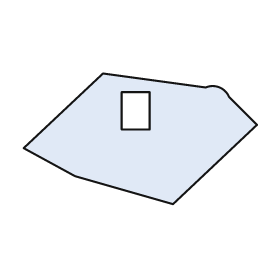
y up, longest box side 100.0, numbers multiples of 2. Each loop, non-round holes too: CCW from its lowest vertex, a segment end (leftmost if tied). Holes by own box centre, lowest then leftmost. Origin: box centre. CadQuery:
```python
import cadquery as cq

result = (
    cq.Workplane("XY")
    .moveTo(14.0, -28.0)
    .lineTo(50.0, 6.0)
    .lineTo(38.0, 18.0)
    .threePointArc((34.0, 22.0), (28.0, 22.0))
    .lineTo(-16.0, 28.0)
    .lineTo(-50.0, -4.0)
    .lineTo(-28.0, -16.0)
    .close()
    .moveTo(-8.0, 4.0)
    .lineTo(4.0, 4.0)
    .lineTo(4.0, 20.0)
    .lineTo(-8.0, 20.0)
    .close()
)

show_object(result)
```